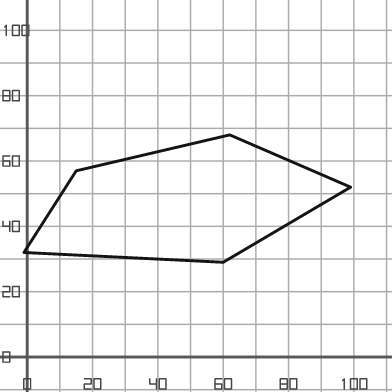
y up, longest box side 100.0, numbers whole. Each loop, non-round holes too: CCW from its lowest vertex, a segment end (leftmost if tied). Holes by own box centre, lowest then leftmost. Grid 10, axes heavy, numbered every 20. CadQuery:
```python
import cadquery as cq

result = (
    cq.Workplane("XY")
    .moveTo(60.0, 29.0)
    .lineTo(99.0, 52.0)
    .lineTo(62.0, 68.0)
    .lineTo(15.0, 57.0)
    .lineTo(-1.0, 32.0)
    .close()
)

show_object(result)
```